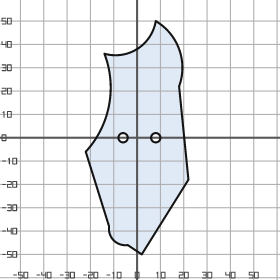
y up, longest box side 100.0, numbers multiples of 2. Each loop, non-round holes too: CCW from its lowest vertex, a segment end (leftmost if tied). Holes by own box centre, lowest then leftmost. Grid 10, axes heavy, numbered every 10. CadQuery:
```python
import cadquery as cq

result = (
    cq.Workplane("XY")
    .moveTo(2.0, -50.0)
    .lineTo(22.0, -18.0)
    .lineTo(18.0, 22.0)
    .threePointArc((18.0, 38.0), (8.0, 50.0))
    .threePointArc((0.0, 38.0), (-14.0, 36.0))
    .threePointArc((-12.0, 14.0), (-22.0, -6.0))
    .lineTo(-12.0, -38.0)
    .threePointArc((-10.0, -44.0), (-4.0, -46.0))
    .close()
    .moveTo(-6.0, 0.0)
    .circle(2.0)
    .moveTo(8.0, 0.0)
    .circle(2.0)
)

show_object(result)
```